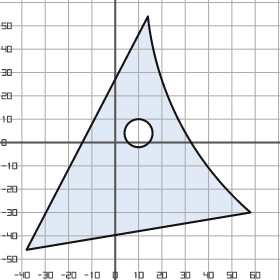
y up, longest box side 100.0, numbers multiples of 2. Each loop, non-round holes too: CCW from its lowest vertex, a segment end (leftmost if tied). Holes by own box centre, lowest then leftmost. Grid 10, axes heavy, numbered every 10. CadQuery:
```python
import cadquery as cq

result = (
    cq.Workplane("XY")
    .moveTo(-38.0, -46.0)
    .lineTo(58.0, -30.0)
    .threePointArc((28.0, 8.0), (14.0, 54.0))
    .close()
    .moveTo(10.0, 4.0)
    .circle(6.0)
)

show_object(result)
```